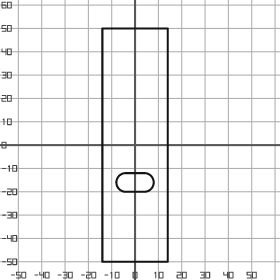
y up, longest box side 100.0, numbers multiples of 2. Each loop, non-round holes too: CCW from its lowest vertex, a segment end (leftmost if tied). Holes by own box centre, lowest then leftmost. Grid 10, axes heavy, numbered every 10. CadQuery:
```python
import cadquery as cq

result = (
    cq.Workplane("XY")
    .moveTo(-14.0, -50.0)
    .lineTo(14.0, -50.0)
    .lineTo(14.0, 50.0)
    .lineTo(-14.0, 50.0)
    .close()
    .moveTo(-4.0, -20.0)
    .lineTo(4.0, -20.0)
    .threePointArc((8.0, -16.0), (4.0, -12.0))
    .lineTo(-4.0, -12.0)
    .threePointArc((-8.0, -16.0), (-4.0, -20.0))
    .close()
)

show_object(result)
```